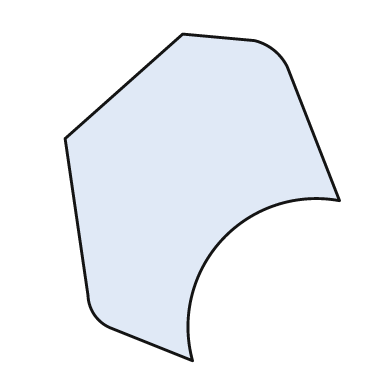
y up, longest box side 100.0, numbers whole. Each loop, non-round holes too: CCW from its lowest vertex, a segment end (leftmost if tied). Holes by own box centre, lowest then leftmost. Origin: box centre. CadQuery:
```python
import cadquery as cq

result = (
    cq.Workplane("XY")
    .moveTo(-3.0, -50.0)
    .threePointArc((6.0, -13.0), (42.0, -1.0))
    .lineTo(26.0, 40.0)
    .threePointArc((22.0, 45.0), (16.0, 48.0))
    .lineTo(-6.0, 50.0)
    .lineTo(-42.0, 18.0)
    .lineTo(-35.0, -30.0)
    .threePointArc((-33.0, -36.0), (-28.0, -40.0))
    .close()
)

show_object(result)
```